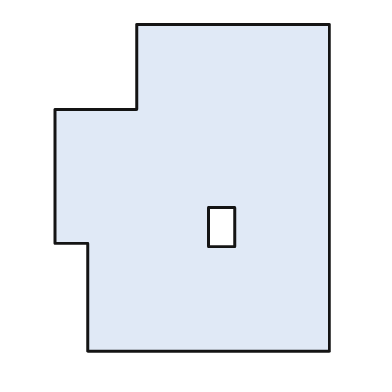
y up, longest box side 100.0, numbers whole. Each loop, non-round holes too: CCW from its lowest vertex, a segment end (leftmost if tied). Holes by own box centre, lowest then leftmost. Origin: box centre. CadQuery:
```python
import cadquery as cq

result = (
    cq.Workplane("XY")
    .moveTo(-32.0, -50.0)
    .lineTo(42.0, -50.0)
    .lineTo(42.0, 50.0)
    .lineTo(-17.0, 50.0)
    .lineTo(-17.0, 24.0)
    .lineTo(-42.0, 24.0)
    .lineTo(-42.0, -17.0)
    .lineTo(-32.0, -17.0)
    .close()
    .moveTo(5.0, -18.0)
    .lineTo(13.0, -18.0)
    .lineTo(13.0, -6.0)
    .lineTo(5.0, -6.0)
    .close()
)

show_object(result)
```